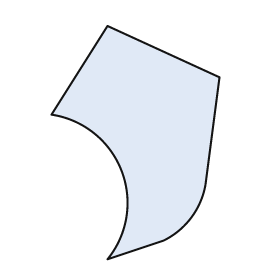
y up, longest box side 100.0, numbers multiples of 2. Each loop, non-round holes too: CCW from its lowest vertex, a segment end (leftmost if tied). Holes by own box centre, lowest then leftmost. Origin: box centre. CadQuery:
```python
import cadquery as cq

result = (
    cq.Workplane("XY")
    .moveTo(-12.0, -50.0)
    .lineTo(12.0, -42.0)
    .threePointArc((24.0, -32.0), (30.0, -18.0))
    .lineTo(36.0, 28.0)
    .lineTo(-12.0, 50.0)
    .lineTo(-36.0, 12.0)
    .threePointArc((-6.0, -12.0), (-12.0, -50.0))
    .close()
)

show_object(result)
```